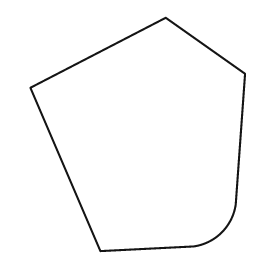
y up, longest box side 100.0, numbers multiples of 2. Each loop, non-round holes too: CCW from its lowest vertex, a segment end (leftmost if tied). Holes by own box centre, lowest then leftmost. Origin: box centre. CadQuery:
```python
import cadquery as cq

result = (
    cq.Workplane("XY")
    .moveTo(-16.0, -50.0)
    .lineTo(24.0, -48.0)
    .threePointArc((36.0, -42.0), (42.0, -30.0))
    .lineTo(46.0, 26.0)
    .lineTo(12.0, 50.0)
    .lineTo(-46.0, 20.0)
    .close()
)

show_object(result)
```